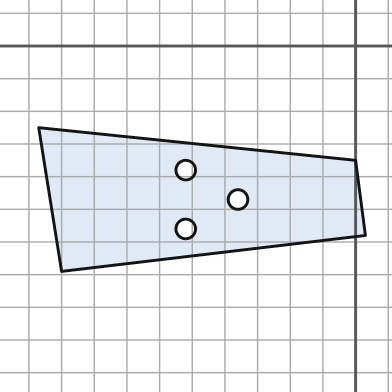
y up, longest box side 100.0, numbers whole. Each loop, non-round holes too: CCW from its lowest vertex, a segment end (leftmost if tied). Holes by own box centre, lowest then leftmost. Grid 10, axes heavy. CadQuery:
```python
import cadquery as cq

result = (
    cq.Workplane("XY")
    .moveTo(-90.0, -69.0)
    .lineTo(3.0, -58.0)
    .lineTo(0.0, -35.0)
    .lineTo(-97.0, -25.0)
    .close()
    .moveTo(-52.0, -56.0)
    .circle(3.0)
    .moveTo(-36.0, -47.0)
    .circle(3.0)
    .moveTo(-52.0, -38.0)
    .circle(3.0)
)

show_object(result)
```